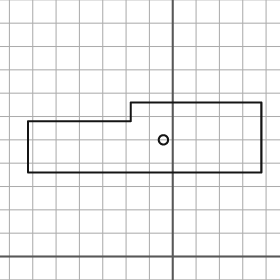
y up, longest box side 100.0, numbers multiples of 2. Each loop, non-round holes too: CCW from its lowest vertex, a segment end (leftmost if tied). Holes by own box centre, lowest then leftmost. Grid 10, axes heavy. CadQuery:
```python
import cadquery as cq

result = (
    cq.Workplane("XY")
    .moveTo(-62.0, 36.0)
    .lineTo(38.0, 36.0)
    .lineTo(38.0, 66.0)
    .lineTo(-18.0, 66.0)
    .lineTo(-18.0, 58.0)
    .lineTo(-62.0, 58.0)
    .close()
    .moveTo(-4.0, 50.0)
    .circle(2.0)
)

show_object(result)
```